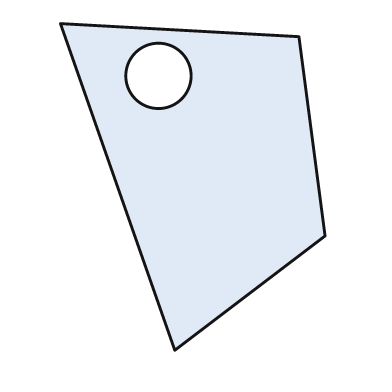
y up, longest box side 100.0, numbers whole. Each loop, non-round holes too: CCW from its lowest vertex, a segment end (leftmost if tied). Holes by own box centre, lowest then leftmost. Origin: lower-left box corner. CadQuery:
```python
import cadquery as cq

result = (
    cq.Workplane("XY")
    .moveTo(35.0, 0.0)
    .lineTo(81.0, 35.0)
    .lineTo(73.0, 96.0)
    .lineTo(0.0, 100.0)
    .close()
    .moveTo(30.0, 84.0)
    .circle(10.0)
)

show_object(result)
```